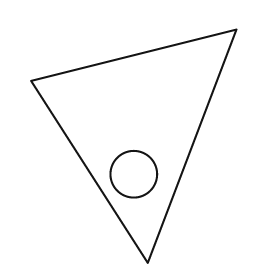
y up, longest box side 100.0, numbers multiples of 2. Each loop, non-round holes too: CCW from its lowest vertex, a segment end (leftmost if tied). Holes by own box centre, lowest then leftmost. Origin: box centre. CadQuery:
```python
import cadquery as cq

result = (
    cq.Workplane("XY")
    .moveTo(6.0, -50.0)
    .lineTo(44.0, 50.0)
    .lineTo(-44.0, 28.0)
    .close()
    .moveTo(0.0, -12.0)
    .circle(10.0)
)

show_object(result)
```